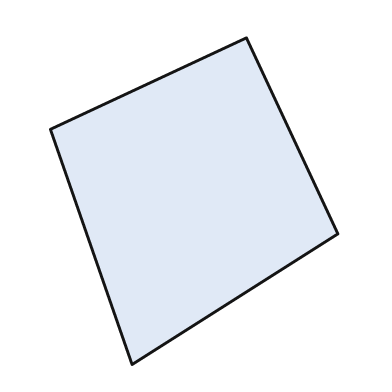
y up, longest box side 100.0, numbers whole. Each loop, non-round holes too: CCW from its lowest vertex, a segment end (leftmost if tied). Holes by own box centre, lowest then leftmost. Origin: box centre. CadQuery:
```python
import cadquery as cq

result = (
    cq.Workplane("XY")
    .moveTo(-19.0, -50.0)
    .lineTo(44.0, -10.0)
    .lineTo(16.0, 50.0)
    .lineTo(-44.0, 22.0)
    .close()
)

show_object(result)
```